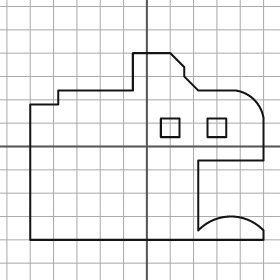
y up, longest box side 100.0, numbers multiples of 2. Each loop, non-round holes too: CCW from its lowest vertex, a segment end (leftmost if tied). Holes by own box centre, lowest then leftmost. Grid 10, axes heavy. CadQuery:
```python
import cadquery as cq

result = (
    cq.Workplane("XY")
    .moveTo(-50.0, -40.0)
    .lineTo(50.0, -40.0)
    .lineTo(50.0, -36.0)
    .threePointArc((36.0, -30.0), (22.0, -36.0))
    .lineTo(22.0, -6.0)
    .lineTo(50.0, -6.0)
    .lineTo(50.0, 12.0)
    .threePointArc((46.0, 20.0), (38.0, 24.0))
    .lineTo(22.0, 24.0)
    .lineTo(16.0, 30.0)
    .lineTo(16.0, 34.0)
    .lineTo(10.0, 40.0)
    .lineTo(-6.0, 40.0)
    .lineTo(-6.0, 24.0)
    .lineTo(-38.0, 24.0)
    .lineTo(-38.0, 18.0)
    .lineTo(-50.0, 18.0)
    .close()
    .moveTo(6.0, 4.0)
    .lineTo(14.0, 4.0)
    .lineTo(14.0, 12.0)
    .lineTo(6.0, 12.0)
    .close()
    .moveTo(26.0, 4.0)
    .lineTo(34.0, 4.0)
    .lineTo(34.0, 12.0)
    .lineTo(26.0, 12.0)
    .close()
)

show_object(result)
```